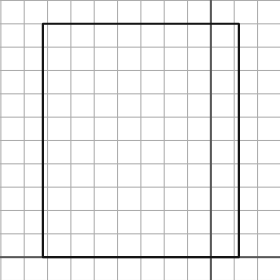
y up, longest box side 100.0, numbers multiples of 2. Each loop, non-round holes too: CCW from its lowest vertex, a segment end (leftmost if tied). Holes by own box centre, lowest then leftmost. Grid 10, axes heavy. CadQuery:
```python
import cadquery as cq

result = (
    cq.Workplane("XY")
    .moveTo(-72.0, 0.0)
    .lineTo(12.0, 0.0)
    .lineTo(12.0, 100.0)
    .lineTo(-72.0, 100.0)
    .close()
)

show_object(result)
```